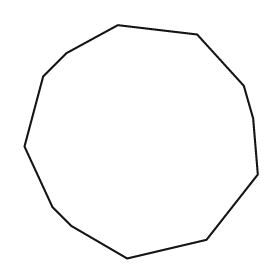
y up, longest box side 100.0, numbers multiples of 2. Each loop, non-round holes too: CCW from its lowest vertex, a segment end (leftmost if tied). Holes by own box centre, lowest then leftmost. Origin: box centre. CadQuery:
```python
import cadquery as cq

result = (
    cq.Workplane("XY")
    .moveTo(-6.0, -50.0)
    .lineTo(28.0, -42.0)
    .lineTo(50.0, -14.0)
    .lineTo(48.0, 10.0)
    .lineTo(44.0, 24.0)
    .lineTo(24.0, 46.0)
    .lineTo(-10.0, 50.0)
    .lineTo(-32.0, 38.0)
    .lineTo(-42.0, 28.0)
    .lineTo(-50.0, -2.0)
    .lineTo(-38.0, -28.0)
    .lineTo(-30.0, -36.0)
    .close()
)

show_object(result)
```